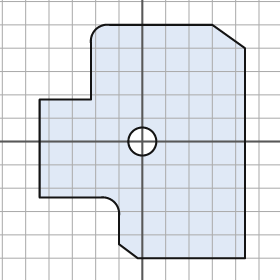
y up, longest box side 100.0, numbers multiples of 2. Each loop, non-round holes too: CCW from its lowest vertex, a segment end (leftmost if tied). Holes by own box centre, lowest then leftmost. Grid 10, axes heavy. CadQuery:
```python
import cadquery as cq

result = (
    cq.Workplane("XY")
    .moveTo(-2.0, -50.0)
    .lineTo(44.0, -50.0)
    .lineTo(44.0, 40.0)
    .lineTo(30.0, 50.0)
    .lineTo(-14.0, 50.0)
    .threePointArc((-20.0, 48.0), (-22.0, 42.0))
    .lineTo(-22.0, 18.0)
    .lineTo(-44.0, 18.0)
    .lineTo(-44.0, -24.0)
    .lineTo(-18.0, -24.0)
    .threePointArc((-12.0, -26.0), (-10.0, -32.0))
    .lineTo(-10.0, -44.0)
    .close()
    .moveTo(0.0, 0.0)
    .circle(6.0)
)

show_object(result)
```